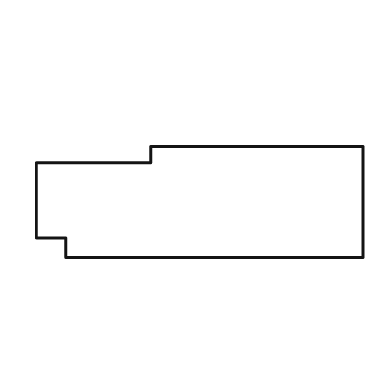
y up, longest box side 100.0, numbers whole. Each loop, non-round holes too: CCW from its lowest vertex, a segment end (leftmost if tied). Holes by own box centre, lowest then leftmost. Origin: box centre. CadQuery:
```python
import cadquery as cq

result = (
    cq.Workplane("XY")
    .moveTo(-41.0, -17.0)
    .lineTo(50.0, -17.0)
    .lineTo(50.0, 17.0)
    .lineTo(-15.0, 17.0)
    .lineTo(-15.0, 12.0)
    .lineTo(-50.0, 12.0)
    .lineTo(-50.0, -11.0)
    .lineTo(-41.0, -11.0)
    .close()
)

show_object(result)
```